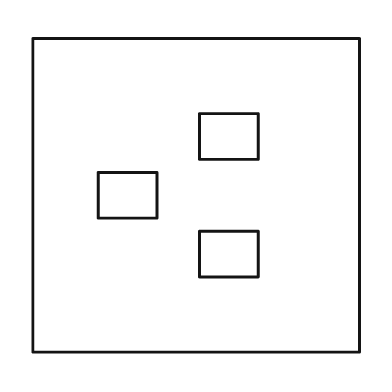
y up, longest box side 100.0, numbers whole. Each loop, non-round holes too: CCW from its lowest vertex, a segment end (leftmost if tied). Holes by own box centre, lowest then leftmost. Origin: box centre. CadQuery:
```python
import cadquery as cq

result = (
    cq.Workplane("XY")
    .moveTo(-50.0, -48.0)
    .lineTo(50.0, -48.0)
    .lineTo(50.0, 48.0)
    .lineTo(-50.0, 48.0)
    .close()
    .moveTo(1.0, -25.0)
    .lineTo(19.0, -25.0)
    .lineTo(19.0, -11.0)
    .lineTo(1.0, -11.0)
    .close()
    .moveTo(-30.0, -7.0)
    .lineTo(-12.0, -7.0)
    .lineTo(-12.0, 7.0)
    .lineTo(-30.0, 7.0)
    .close()
    .moveTo(1.0, 11.0)
    .lineTo(19.0, 11.0)
    .lineTo(19.0, 25.0)
    .lineTo(1.0, 25.0)
    .close()
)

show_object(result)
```